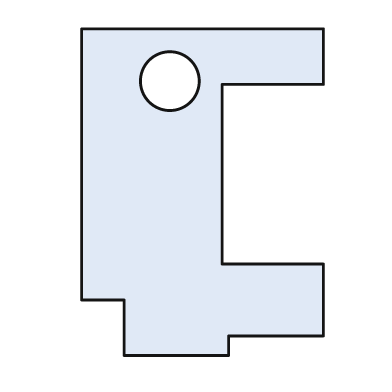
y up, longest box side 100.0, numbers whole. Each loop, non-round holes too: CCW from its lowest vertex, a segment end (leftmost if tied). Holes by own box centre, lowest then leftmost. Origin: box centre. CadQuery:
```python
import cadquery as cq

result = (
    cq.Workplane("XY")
    .moveTo(-24.0, -50.0)
    .lineTo(8.0, -50.0)
    .lineTo(8.0, -44.0)
    .lineTo(37.0, -44.0)
    .lineTo(37.0, -22.0)
    .lineTo(6.0, -22.0)
    .lineTo(6.0, 33.0)
    .lineTo(37.0, 33.0)
    .lineTo(37.0, 50.0)
    .lineTo(-37.0, 50.0)
    .lineTo(-37.0, -33.0)
    .lineTo(-24.0, -33.0)
    .close()
    .moveTo(-10.0, 34.0)
    .circle(9.0)
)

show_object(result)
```